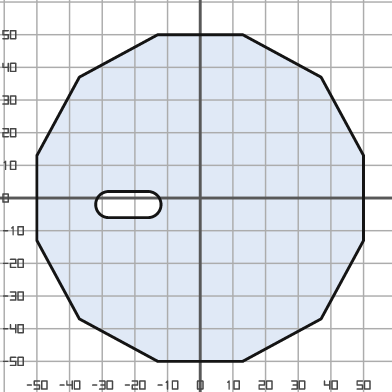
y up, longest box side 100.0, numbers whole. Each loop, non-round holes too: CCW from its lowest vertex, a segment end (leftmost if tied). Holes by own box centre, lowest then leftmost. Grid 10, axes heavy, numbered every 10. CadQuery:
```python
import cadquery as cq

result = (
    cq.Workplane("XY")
    .moveTo(-13.0, -50.0)
    .lineTo(13.0, -50.0)
    .lineTo(37.0, -37.0)
    .lineTo(50.0, -13.0)
    .lineTo(50.0, 13.0)
    .lineTo(37.0, 37.0)
    .lineTo(13.0, 50.0)
    .lineTo(-13.0, 50.0)
    .lineTo(-37.0, 37.0)
    .lineTo(-50.0, 13.0)
    .lineTo(-50.0, -13.0)
    .lineTo(-37.0, -37.0)
    .close()
    .moveTo(-28.0, -6.0)
    .lineTo(-16.0, -6.0)
    .threePointArc((-12.0, -2.0), (-16.0, 2.0))
    .lineTo(-28.0, 2.0)
    .threePointArc((-32.0, -2.0), (-28.0, -6.0))
    .close()
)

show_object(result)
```